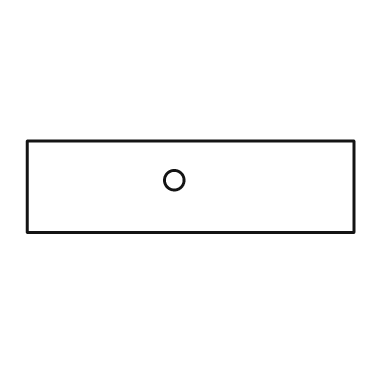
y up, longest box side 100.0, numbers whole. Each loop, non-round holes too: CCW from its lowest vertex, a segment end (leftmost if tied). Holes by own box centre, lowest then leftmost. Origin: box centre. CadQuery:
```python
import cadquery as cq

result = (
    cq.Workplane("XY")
    .moveTo(-50.0, -14.0)
    .lineTo(50.0, -14.0)
    .lineTo(50.0, 14.0)
    .lineTo(-50.0, 14.0)
    .close()
    .moveTo(-5.0, 2.0)
    .circle(3.0)
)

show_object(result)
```